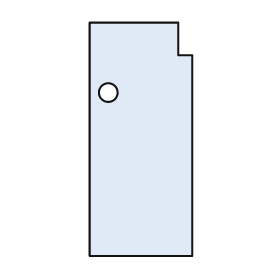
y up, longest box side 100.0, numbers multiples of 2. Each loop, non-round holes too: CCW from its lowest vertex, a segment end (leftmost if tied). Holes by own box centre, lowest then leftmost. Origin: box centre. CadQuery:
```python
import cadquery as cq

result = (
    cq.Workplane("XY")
    .moveTo(-22.0, -50.0)
    .lineTo(22.0, -50.0)
    .lineTo(22.0, 36.0)
    .lineTo(16.0, 36.0)
    .lineTo(16.0, 50.0)
    .lineTo(-22.0, 50.0)
    .close()
    .moveTo(-14.0, 20.0)
    .circle(4.0)
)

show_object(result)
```